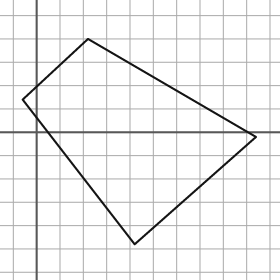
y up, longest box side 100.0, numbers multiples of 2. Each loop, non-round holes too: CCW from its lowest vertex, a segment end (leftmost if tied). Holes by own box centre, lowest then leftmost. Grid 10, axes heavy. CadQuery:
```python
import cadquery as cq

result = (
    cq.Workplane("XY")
    .moveTo(42.0, -48.0)
    .lineTo(94.0, -2.0)
    .lineTo(22.0, 40.0)
    .lineTo(-6.0, 14.0)
    .close()
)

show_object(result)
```